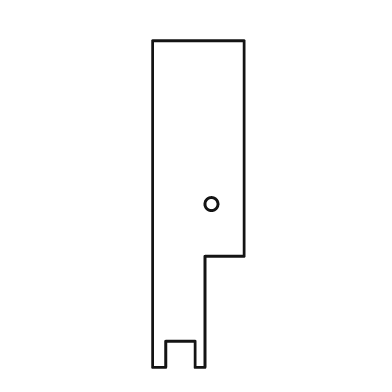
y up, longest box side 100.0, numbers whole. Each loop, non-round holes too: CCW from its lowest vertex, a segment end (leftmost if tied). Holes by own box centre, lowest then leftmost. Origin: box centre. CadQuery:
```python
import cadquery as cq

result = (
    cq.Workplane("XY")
    .moveTo(-14.0, -50.0)
    .lineTo(-10.0, -50.0)
    .lineTo(-10.0, -42.0)
    .lineTo(-1.0, -42.0)
    .lineTo(-1.0, -50.0)
    .lineTo(2.0, -50.0)
    .lineTo(2.0, -16.0)
    .lineTo(14.0, -16.0)
    .lineTo(14.0, 50.0)
    .lineTo(-14.0, 50.0)
    .close()
    .moveTo(4.0, 0.0)
    .circle(2.0)
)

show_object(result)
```